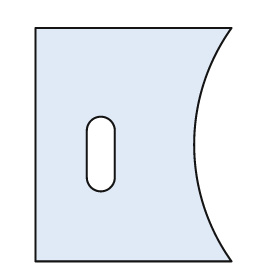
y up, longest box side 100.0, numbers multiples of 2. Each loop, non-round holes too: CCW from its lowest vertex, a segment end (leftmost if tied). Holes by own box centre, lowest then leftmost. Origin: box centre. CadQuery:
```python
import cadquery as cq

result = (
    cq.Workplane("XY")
    .moveTo(-42.0, -50.0)
    .lineTo(42.0, -50.0)
    .threePointArc((26.0, 0.0), (42.0, 50.0))
    .lineTo(-42.0, 50.0)
    .close()
    .moveTo(-20.0, -14.0)
    .threePointArc((-14.0, -20.0), (-8.0, -14.0))
    .lineTo(-8.0, 6.0)
    .threePointArc((-14.0, 12.0), (-20.0, 6.0))
    .close()
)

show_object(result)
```